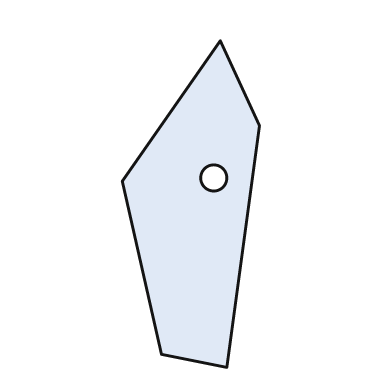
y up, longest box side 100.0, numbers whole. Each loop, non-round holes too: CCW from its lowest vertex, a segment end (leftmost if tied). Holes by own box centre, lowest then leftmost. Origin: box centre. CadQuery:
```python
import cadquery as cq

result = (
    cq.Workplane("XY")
    .moveTo(11.0, -50.0)
    .lineTo(21.0, 24.0)
    .lineTo(9.0, 50.0)
    .lineTo(-21.0, 7.0)
    .lineTo(-9.0, -46.0)
    .close()
    .moveTo(7.0, 8.0)
    .circle(4.0)
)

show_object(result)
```